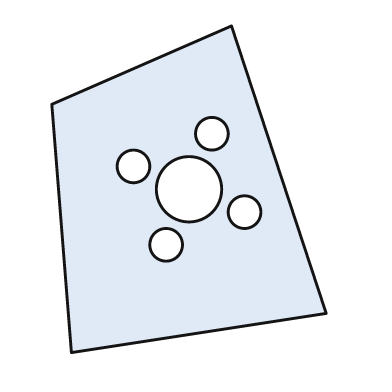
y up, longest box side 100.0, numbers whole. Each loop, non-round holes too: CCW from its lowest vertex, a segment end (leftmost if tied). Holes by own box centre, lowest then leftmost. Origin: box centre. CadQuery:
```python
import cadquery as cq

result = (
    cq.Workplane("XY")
    .moveTo(-36.0, -50.0)
    .lineTo(42.0, -38.0)
    .lineTo(13.0, 50.0)
    .lineTo(-42.0, 26.0)
    .close()
    .moveTo(-7.0, -17.0)
    .circle(5.0)
    .moveTo(17.0, -7.0)
    .circle(5.0)
    .moveTo(0.0, 0.0)
    .circle(10.0)
    .moveTo(-17.0, 7.0)
    .circle(5.0)
    .moveTo(7.0, 17.0)
    .circle(5.0)
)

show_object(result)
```